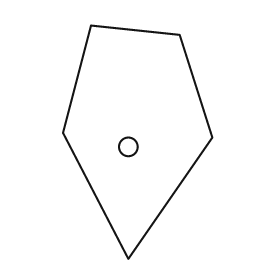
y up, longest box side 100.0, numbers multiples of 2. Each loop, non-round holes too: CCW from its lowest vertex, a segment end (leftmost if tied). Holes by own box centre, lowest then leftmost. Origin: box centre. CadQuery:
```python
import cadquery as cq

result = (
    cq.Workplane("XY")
    .moveTo(-4.0, -50.0)
    .lineTo(32.0, 2.0)
    .lineTo(18.0, 46.0)
    .lineTo(-20.0, 50.0)
    .lineTo(-32.0, 4.0)
    .close()
    .moveTo(-4.0, -2.0)
    .circle(4.0)
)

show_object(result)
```